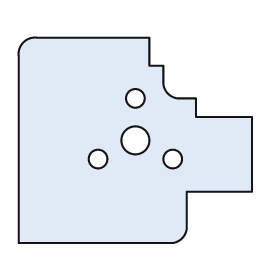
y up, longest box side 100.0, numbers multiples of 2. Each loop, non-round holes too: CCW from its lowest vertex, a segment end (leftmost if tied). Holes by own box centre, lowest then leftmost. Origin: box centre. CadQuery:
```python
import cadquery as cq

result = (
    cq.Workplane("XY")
    .moveTo(-50.0, -44.0)
    .lineTo(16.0, -44.0)
    .threePointArc((20.0, -42.0), (22.0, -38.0))
    .lineTo(22.0, -22.0)
    .lineTo(50.0, -22.0)
    .lineTo(50.0, 10.0)
    .lineTo(26.0, 10.0)
    .lineTo(26.0, 18.0)
    .lineTo(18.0, 18.0)
    .threePointArc((14.0, 20.0), (12.0, 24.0))
    .lineTo(12.0, 32.0)
    .lineTo(6.0, 32.0)
    .lineTo(6.0, 44.0)
    .lineTo(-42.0, 44.0)
    .threePointArc((-48.0, 42.0), (-50.0, 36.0))
    .close()
    .moveTo(-16.0, -8.0)
    .circle(4.0)
    .moveTo(16.0, -8.0)
    .circle(4.0)
    .moveTo(0.0, 0.0)
    .circle(6.0)
    .moveTo(0.0, 18.0)
    .circle(4.0)
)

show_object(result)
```